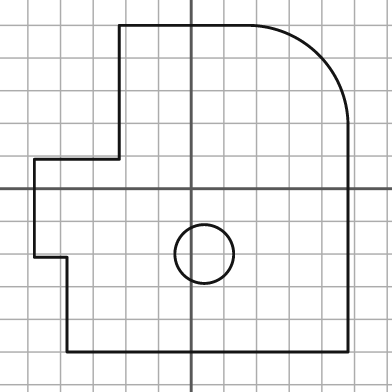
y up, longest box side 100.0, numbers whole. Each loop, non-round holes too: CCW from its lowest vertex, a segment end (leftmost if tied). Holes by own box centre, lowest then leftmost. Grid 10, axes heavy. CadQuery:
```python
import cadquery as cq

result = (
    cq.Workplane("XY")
    .moveTo(-38.0, -50.0)
    .lineTo(48.0, -50.0)
    .lineTo(48.0, 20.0)
    .threePointArc((39.0, 41.0), (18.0, 50.0))
    .lineTo(-22.0, 50.0)
    .lineTo(-22.0, 9.0)
    .lineTo(-48.0, 9.0)
    .lineTo(-48.0, -21.0)
    .lineTo(-38.0, -21.0)
    .close()
    .moveTo(4.0, -20.0)
    .circle(9.0)
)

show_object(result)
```